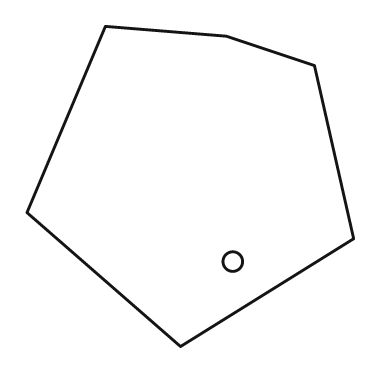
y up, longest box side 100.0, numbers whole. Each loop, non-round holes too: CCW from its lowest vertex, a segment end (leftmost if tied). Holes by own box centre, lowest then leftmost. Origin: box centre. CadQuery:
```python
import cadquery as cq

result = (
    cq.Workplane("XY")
    .moveTo(-3.0, -49.0)
    .lineTo(50.0, -16.0)
    .lineTo(38.0, 37.0)
    .lineTo(11.0, 46.0)
    .lineTo(-26.0, 49.0)
    .lineTo(-50.0, -8.0)
    .close()
    .moveTo(13.0, -23.0)
    .circle(3.0)
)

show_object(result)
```